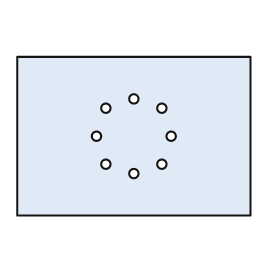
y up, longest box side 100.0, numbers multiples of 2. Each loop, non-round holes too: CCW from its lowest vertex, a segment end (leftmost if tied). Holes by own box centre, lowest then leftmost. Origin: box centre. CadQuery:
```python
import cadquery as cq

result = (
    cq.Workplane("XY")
    .moveTo(-50.0, -34.0)
    .lineTo(50.0, -34.0)
    .lineTo(50.0, 34.0)
    .lineTo(-50.0, 34.0)
    .close()
    .moveTo(0.0, -16.0)
    .circle(2.0)
    .moveTo(-12.0, -12.0)
    .circle(2.0)
    .moveTo(12.0, -12.0)
    .circle(2.0)
    .moveTo(-16.0, 0.0)
    .circle(2.0)
    .moveTo(16.0, 0.0)
    .circle(2.0)
    .moveTo(-12.0, 12.0)
    .circle(2.0)
    .moveTo(12.0, 12.0)
    .circle(2.0)
    .moveTo(0.0, 16.0)
    .circle(2.0)
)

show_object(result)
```